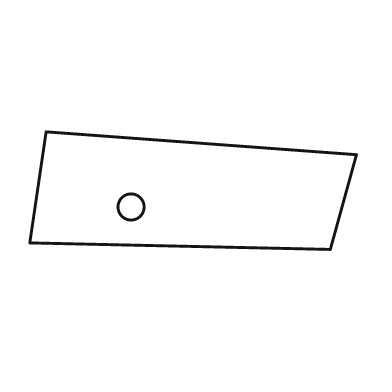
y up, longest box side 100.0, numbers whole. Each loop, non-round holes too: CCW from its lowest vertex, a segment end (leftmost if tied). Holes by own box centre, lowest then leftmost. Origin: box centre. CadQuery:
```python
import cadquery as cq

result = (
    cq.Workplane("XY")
    .moveTo(42.0, -18.0)
    .lineTo(50.0, 11.0)
    .lineTo(-45.0, 18.0)
    .lineTo(-50.0, -16.0)
    .close()
    .moveTo(-19.0, -5.0)
    .circle(4.0)
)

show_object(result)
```